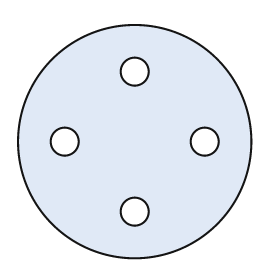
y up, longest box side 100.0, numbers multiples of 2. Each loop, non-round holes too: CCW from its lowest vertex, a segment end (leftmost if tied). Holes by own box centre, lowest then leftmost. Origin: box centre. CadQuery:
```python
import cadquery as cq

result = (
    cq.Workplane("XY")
    .moveTo(0.0, 0.0)
    .circle(50.0)
    .moveTo(0.0, -30.0)
    .circle(6.0)
    .moveTo(-30.0, 0.0)
    .circle(6.0)
    .moveTo(30.0, 0.0)
    .circle(6.0)
    .moveTo(0.0, 30.0)
    .circle(6.0)
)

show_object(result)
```